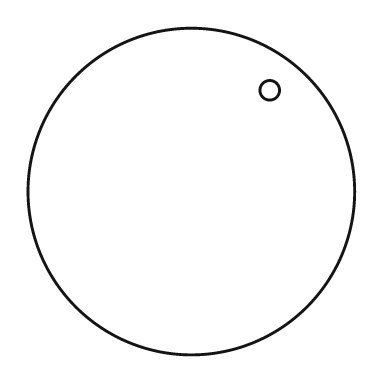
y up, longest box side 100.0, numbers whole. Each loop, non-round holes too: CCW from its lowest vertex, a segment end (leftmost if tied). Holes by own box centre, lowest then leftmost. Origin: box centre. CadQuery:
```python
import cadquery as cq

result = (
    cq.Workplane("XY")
    .moveTo(0.0, 0.0)
    .circle(50.0)
    .moveTo(24.0, 31.0)
    .circle(3.0)
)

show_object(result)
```